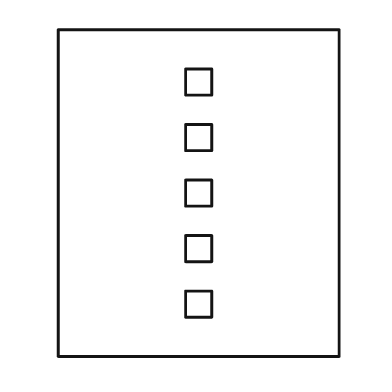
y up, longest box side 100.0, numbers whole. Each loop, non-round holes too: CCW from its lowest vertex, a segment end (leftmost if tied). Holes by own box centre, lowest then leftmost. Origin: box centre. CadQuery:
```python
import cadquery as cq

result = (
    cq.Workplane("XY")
    .moveTo(-43.0, -50.0)
    .lineTo(43.0, -50.0)
    .lineTo(43.0, 50.0)
    .lineTo(-43.0, 50.0)
    .close()
    .moveTo(-4.0, -38.0)
    .lineTo(4.0, -38.0)
    .lineTo(4.0, -30.0)
    .lineTo(-4.0, -30.0)
    .close()
    .moveTo(-4.0, -21.0)
    .lineTo(4.0, -21.0)
    .lineTo(4.0, -13.0)
    .lineTo(-4.0, -13.0)
    .close()
    .moveTo(-4.0, -4.0)
    .lineTo(4.0, -4.0)
    .lineTo(4.0, 4.0)
    .lineTo(-4.0, 4.0)
    .close()
    .moveTo(-4.0, 13.0)
    .lineTo(4.0, 13.0)
    .lineTo(4.0, 21.0)
    .lineTo(-4.0, 21.0)
    .close()
    .moveTo(-4.0, 30.0)
    .lineTo(4.0, 30.0)
    .lineTo(4.0, 38.0)
    .lineTo(-4.0, 38.0)
    .close()
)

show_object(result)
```